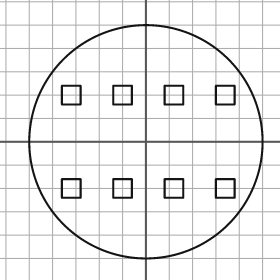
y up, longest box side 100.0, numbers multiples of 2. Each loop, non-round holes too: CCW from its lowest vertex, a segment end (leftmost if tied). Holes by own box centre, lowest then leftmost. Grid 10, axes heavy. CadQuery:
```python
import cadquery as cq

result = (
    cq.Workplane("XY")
    .moveTo(0.0, 0.0)
    .circle(50.0)
    .moveTo(-36.0, -24.0)
    .lineTo(-28.0, -24.0)
    .lineTo(-28.0, -16.0)
    .lineTo(-36.0, -16.0)
    .close()
    .moveTo(-14.0, -24.0)
    .lineTo(-6.0, -24.0)
    .lineTo(-6.0, -16.0)
    .lineTo(-14.0, -16.0)
    .close()
    .moveTo(8.0, -24.0)
    .lineTo(16.0, -24.0)
    .lineTo(16.0, -16.0)
    .lineTo(8.0, -16.0)
    .close()
    .moveTo(30.0, -24.0)
    .lineTo(38.0, -24.0)
    .lineTo(38.0, -16.0)
    .lineTo(30.0, -16.0)
    .close()
    .moveTo(-36.0, 16.0)
    .lineTo(-28.0, 16.0)
    .lineTo(-28.0, 24.0)
    .lineTo(-36.0, 24.0)
    .close()
    .moveTo(-14.0, 16.0)
    .lineTo(-6.0, 16.0)
    .lineTo(-6.0, 24.0)
    .lineTo(-14.0, 24.0)
    .close()
    .moveTo(8.0, 16.0)
    .lineTo(16.0, 16.0)
    .lineTo(16.0, 24.0)
    .lineTo(8.0, 24.0)
    .close()
    .moveTo(30.0, 16.0)
    .lineTo(38.0, 16.0)
    .lineTo(38.0, 24.0)
    .lineTo(30.0, 24.0)
    .close()
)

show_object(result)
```